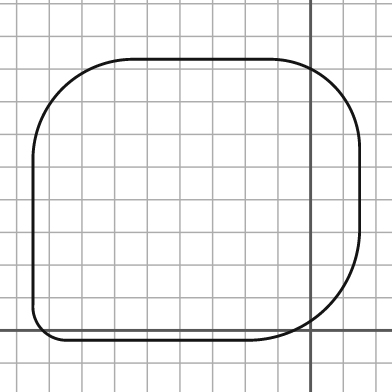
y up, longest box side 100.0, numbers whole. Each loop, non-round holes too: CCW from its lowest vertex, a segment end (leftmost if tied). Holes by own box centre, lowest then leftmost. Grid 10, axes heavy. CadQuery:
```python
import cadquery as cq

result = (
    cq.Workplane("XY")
    .moveTo(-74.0, -3.0)
    .lineTo(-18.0, -3.0)
    .threePointArc((5.0, 7.0), (15.0, 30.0))
    .lineTo(15.0, 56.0)
    .threePointArc((7.0, 75.0), (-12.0, 83.0))
    .lineTo(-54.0, 83.0)
    .threePointArc((-76.0, 74.0), (-85.0, 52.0))
    .lineTo(-85.0, 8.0)
    .threePointArc((-82.0, 0.0), (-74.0, -3.0))
    .close()
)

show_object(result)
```